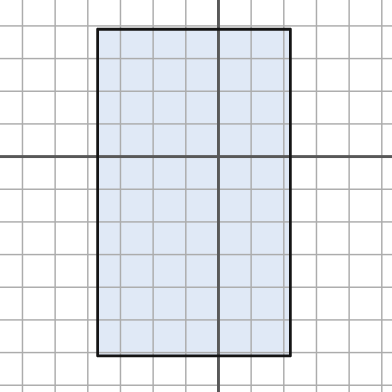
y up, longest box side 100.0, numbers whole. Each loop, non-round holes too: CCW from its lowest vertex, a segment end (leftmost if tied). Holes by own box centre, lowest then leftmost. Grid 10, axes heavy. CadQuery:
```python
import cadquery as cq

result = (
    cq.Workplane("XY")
    .moveTo(-37.0, -61.0)
    .lineTo(22.0, -61.0)
    .lineTo(22.0, 39.0)
    .lineTo(-37.0, 39.0)
    .close()
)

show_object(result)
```